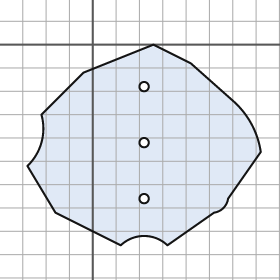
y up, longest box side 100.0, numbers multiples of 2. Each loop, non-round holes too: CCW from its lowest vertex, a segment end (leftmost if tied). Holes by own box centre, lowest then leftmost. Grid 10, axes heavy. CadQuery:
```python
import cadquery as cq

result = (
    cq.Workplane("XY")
    .moveTo(12.0, -86.0)
    .threePointArc((22.0, -82.0), (32.0, -86.0))
    .lineTo(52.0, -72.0)
    .threePointArc((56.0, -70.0), (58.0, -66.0))
    .lineTo(72.0, -46.0)
    .threePointArc((68.0, -34.0), (60.0, -24.0))
    .lineTo(42.0, -8.0)
    .lineTo(26.0, 0.0)
    .lineTo(-4.0, -12.0)
    .lineTo(-22.0, -30.0)
    .threePointArc((-22.0, -42.0), (-28.0, -52.0))
    .lineTo(-16.0, -72.0)
    .close()
    .moveTo(22.0, -66.0)
    .circle(2.0)
    .moveTo(22.0, -42.0)
    .circle(2.0)
    .moveTo(22.0, -18.0)
    .circle(2.0)
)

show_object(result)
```